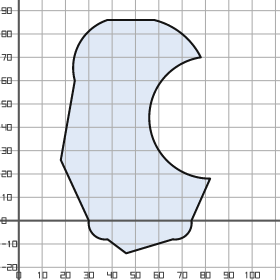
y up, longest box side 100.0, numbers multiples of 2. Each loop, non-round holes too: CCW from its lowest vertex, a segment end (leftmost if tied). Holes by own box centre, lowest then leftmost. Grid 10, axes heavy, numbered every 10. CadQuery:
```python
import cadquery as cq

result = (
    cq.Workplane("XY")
    .moveTo(46.0, -14.0)
    .lineTo(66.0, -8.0)
    .threePointArc((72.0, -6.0), (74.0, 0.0))
    .lineTo(82.0, 18.0)
    .threePointArc((56.0, 42.0), (78.0, 70.0))
    .threePointArc((70.0, 80.0), (58.0, 86.0))
    .lineTo(38.0, 86.0)
    .threePointArc((26.0, 76.0), (24.0, 60.0))
    .lineTo(18.0, 26.0)
    .lineTo(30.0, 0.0)
    .threePointArc((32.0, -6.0), (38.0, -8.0))
    .close()
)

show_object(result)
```